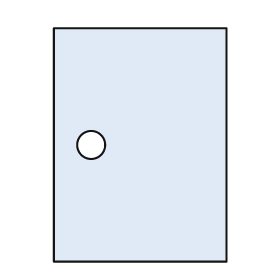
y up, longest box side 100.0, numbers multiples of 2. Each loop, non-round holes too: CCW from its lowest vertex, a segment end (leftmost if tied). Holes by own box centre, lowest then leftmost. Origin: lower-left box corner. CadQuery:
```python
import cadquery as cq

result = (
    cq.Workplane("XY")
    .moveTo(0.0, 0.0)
    .lineTo(74.0, 0.0)
    .lineTo(74.0, 100.0)
    .lineTo(0.0, 100.0)
    .close()
    .moveTo(16.0, 50.0)
    .circle(6.0)
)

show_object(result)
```